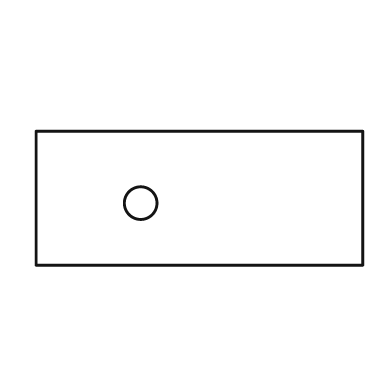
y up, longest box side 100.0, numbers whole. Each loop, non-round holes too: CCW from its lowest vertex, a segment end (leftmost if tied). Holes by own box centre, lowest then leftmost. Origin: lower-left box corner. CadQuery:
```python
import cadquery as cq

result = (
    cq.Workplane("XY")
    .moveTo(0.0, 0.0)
    .lineTo(100.0, 0.0)
    .lineTo(100.0, 41.0)
    .lineTo(0.0, 41.0)
    .close()
    .moveTo(32.0, 19.0)
    .circle(5.0)
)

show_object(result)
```